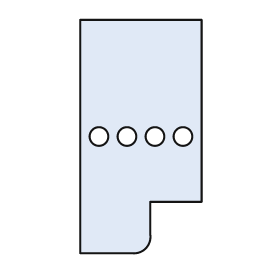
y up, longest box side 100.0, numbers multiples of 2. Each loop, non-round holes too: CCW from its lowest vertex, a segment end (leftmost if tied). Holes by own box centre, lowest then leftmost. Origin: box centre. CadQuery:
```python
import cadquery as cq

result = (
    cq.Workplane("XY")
    .moveTo(-26.0, -50.0)
    .lineTo(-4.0, -50.0)
    .threePointArc((2.0, -48.0), (4.0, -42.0))
    .lineTo(4.0, -28.0)
    .lineTo(26.0, -28.0)
    .lineTo(26.0, 50.0)
    .lineTo(-26.0, 50.0)
    .close()
    .moveTo(-18.0, 0.0)
    .circle(4.0)
    .moveTo(-6.0, 0.0)
    .circle(4.0)
    .moveTo(6.0, 0.0)
    .circle(4.0)
    .moveTo(18.0, 0.0)
    .circle(4.0)
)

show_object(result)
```